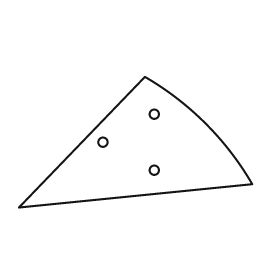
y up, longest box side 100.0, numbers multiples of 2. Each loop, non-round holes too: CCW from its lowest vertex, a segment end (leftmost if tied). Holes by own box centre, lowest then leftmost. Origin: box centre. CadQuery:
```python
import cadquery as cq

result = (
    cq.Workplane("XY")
    .moveTo(-50.0, -28.0)
    .lineTo(50.0, -18.0)
    .threePointArc((30.0, 8.0), (4.0, 28.0))
    .close()
    .moveTo(8.0, -12.0)
    .circle(2.0)
    .moveTo(-14.0, 0.0)
    .circle(2.0)
    .moveTo(8.0, 12.0)
    .circle(2.0)
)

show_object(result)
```